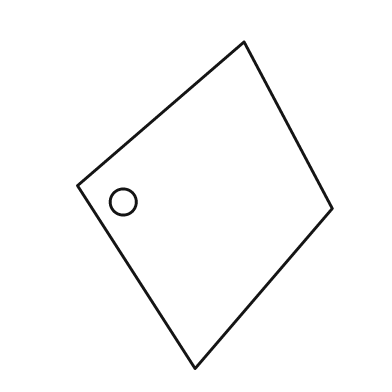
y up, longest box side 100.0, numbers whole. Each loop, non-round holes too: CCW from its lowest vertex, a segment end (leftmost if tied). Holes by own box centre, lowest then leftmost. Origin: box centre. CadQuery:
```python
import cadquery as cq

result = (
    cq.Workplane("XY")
    .moveTo(-3.0, -50.0)
    .lineTo(39.0, -1.0)
    .lineTo(12.0, 50.0)
    .lineTo(-39.0, 6.0)
    .close()
    .moveTo(-25.0, 1.0)
    .circle(4.0)
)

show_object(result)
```